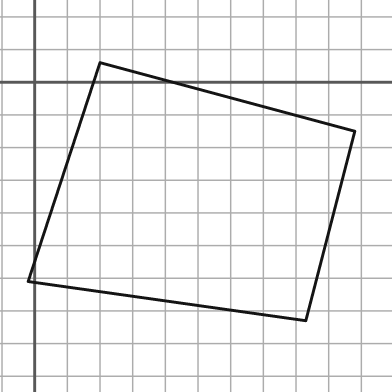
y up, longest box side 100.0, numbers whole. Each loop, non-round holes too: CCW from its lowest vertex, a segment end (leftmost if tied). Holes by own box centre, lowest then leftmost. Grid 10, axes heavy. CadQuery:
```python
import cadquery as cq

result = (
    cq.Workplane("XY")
    .moveTo(83.0, -73.0)
    .lineTo(98.0, -15.0)
    .lineTo(20.0, 6.0)
    .lineTo(-2.0, -61.0)
    .close()
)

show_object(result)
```